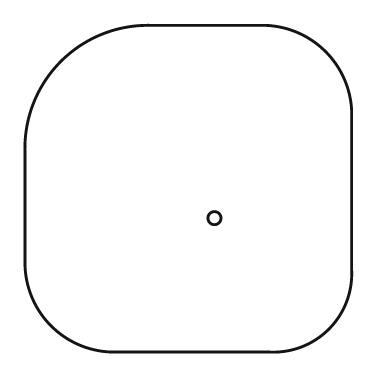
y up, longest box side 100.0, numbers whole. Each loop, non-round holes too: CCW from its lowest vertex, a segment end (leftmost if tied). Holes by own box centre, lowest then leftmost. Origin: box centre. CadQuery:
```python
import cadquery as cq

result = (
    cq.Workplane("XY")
    .moveTo(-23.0, -50.0)
    .lineTo(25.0, -50.0)
    .threePointArc((43.0, -43.0), (50.0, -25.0))
    .lineTo(50.0, 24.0)
    .threePointArc((42.0, 42.0), (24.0, 50.0))
    .lineTo(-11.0, 50.0)
    .threePointArc((-39.0, 39.0), (-50.0, 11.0))
    .lineTo(-50.0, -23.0)
    .threePointArc((-42.0, -42.0), (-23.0, -50.0))
    .close()
    .moveTo(8.0, -9.0)
    .circle(2.0)
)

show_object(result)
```